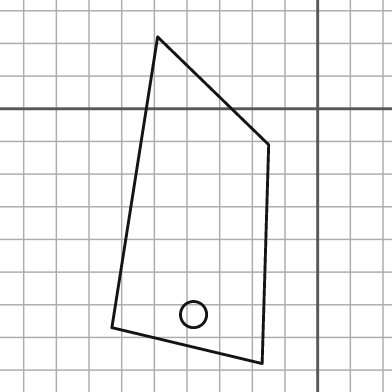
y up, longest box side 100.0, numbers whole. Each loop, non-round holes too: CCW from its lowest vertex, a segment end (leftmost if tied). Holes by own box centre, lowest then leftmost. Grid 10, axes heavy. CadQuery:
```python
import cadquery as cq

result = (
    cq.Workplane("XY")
    .moveTo(-17.0, -78.0)
    .lineTo(-15.0, -11.0)
    .lineTo(-49.0, 22.0)
    .lineTo(-63.0, -67.0)
    .close()
    .moveTo(-38.0, -63.0)
    .circle(4.0)
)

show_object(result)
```